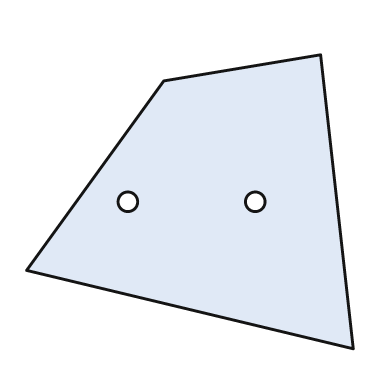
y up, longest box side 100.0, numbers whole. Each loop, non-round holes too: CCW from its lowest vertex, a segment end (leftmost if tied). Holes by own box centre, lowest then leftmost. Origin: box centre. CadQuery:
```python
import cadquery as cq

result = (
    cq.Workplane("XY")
    .moveTo(50.0, -45.0)
    .lineTo(40.0, 45.0)
    .lineTo(-8.0, 37.0)
    .lineTo(-50.0, -21.0)
    .close()
    .moveTo(-19.0, 0.0)
    .circle(3.0)
    .moveTo(20.0, 0.0)
    .circle(3.0)
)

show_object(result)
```